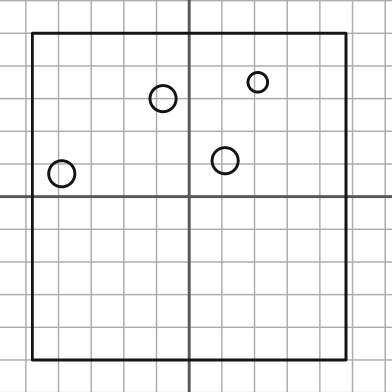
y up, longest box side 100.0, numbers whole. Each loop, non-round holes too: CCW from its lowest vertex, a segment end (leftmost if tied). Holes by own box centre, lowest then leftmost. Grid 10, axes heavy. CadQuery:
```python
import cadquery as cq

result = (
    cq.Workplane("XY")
    .moveTo(-48.0, -50.0)
    .lineTo(48.0, -50.0)
    .lineTo(48.0, 50.0)
    .lineTo(-48.0, 50.0)
    .close()
    .moveTo(-39.0, 7.0)
    .circle(4.0)
    .moveTo(11.0, 11.0)
    .circle(4.0)
    .moveTo(-8.0, 30.0)
    .circle(4.0)
    .moveTo(21.0, 35.0)
    .circle(3.0)
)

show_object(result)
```